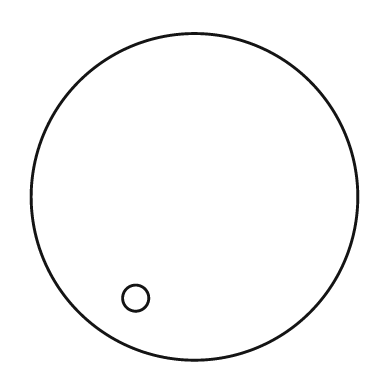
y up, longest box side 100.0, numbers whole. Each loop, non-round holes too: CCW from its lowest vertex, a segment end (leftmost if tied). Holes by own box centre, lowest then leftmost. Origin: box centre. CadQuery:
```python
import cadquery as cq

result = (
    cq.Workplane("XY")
    .moveTo(0.0, 0.0)
    .circle(50.0)
    .moveTo(-18.0, -31.0)
    .circle(4.0)
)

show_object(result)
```